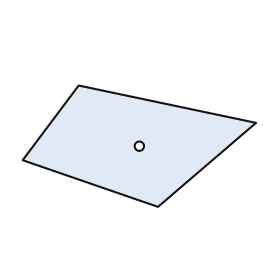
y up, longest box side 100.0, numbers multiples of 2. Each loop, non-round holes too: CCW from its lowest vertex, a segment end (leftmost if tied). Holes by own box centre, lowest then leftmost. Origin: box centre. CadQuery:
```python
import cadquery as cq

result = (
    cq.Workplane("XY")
    .moveTo(8.0, -26.0)
    .lineTo(50.0, 10.0)
    .lineTo(-26.0, 26.0)
    .lineTo(-50.0, -6.0)
    .close()
    .moveTo(0.0, 0.0)
    .circle(2.0)
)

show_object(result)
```